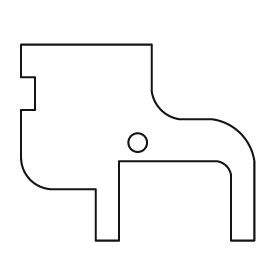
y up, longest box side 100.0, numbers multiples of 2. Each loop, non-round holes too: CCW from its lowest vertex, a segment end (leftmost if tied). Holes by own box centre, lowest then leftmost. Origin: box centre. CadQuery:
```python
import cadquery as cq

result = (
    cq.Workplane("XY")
    .moveTo(-18.0, -42.0)
    .lineTo(-8.0, -42.0)
    .lineTo(-8.0, -8.0)
    .lineTo(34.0, -8.0)
    .threePointArc((38.0, -10.0), (40.0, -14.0))
    .lineTo(40.0, -42.0)
    .lineTo(50.0, -42.0)
    .lineTo(50.0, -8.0)
    .threePointArc((44.0, 4.0), (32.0, 10.0))
    .lineTo(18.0, 10.0)
    .threePointArc((10.0, 14.0), (6.0, 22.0))
    .lineTo(6.0, 42.0)
    .lineTo(-50.0, 42.0)
    .lineTo(-50.0, 28.0)
    .lineTo(-44.0, 28.0)
    .lineTo(-44.0, 14.0)
    .lineTo(-50.0, 14.0)
    .lineTo(-50.0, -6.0)
    .threePointArc((-46.0, -16.0), (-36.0, -20.0))
    .lineTo(-18.0, -20.0)
    .close()
    .moveTo(0.0, 0.0)
    .circle(4.0)
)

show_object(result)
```